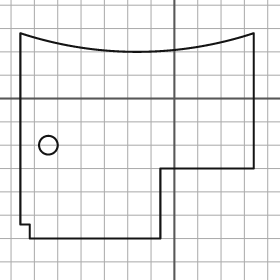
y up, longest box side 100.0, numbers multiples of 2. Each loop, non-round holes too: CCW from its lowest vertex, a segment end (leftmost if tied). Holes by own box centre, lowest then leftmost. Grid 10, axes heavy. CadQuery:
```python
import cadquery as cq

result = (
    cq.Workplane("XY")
    .moveTo(-62.0, -60.0)
    .lineTo(-6.0, -60.0)
    .lineTo(-6.0, -30.0)
    .lineTo(34.0, -30.0)
    .lineTo(34.0, 28.0)
    .threePointArc((-16.0, 20.0), (-66.0, 28.0))
    .lineTo(-66.0, -54.0)
    .lineTo(-62.0, -54.0)
    .close()
    .moveTo(-54.0, -20.0)
    .circle(4.0)
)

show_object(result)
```